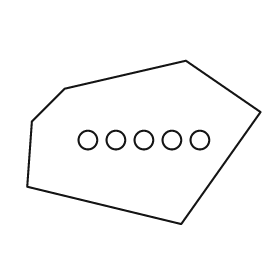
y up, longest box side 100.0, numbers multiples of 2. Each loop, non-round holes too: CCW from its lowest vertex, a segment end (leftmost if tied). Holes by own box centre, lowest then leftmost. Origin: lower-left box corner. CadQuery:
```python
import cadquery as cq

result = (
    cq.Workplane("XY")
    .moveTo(66.0, 0.0)
    .lineTo(100.0, 48.0)
    .lineTo(68.0, 70.0)
    .lineTo(16.0, 58.0)
    .lineTo(2.0, 44.0)
    .lineTo(0.0, 16.0)
    .close()
    .moveTo(26.0, 36.0)
    .circle(4.0)
    .moveTo(38.0, 36.0)
    .circle(4.0)
    .moveTo(50.0, 36.0)
    .circle(4.0)
    .moveTo(62.0, 36.0)
    .circle(4.0)
    .moveTo(74.0, 36.0)
    .circle(4.0)
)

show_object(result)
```